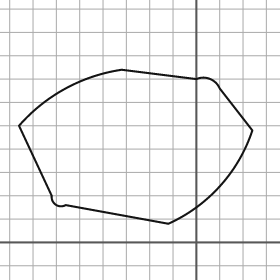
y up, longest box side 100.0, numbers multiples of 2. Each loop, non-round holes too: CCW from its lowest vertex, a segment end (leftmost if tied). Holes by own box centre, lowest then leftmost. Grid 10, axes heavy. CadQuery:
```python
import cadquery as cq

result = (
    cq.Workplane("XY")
    .moveTo(-12.0, 8.0)
    .threePointArc((10.0, 24.0), (24.0, 48.0))
    .lineTo(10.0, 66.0)
    .threePointArc((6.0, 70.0), (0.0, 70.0))
    .lineTo(-32.0, 74.0)
    .threePointArc((-56.0, 66.0), (-76.0, 50.0))
    .lineTo(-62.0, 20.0)
    .threePointArc((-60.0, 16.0), (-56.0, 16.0))
    .close()
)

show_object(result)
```